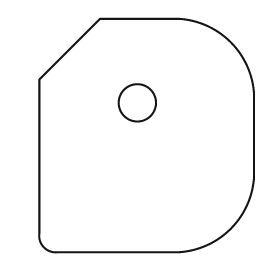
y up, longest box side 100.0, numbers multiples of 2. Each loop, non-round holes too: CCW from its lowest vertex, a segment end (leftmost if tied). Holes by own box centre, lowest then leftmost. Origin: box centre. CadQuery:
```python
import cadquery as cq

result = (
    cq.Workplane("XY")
    .moveTo(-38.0, -50.0)
    .lineTo(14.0, -50.0)
    .threePointArc((36.0, -40.0), (46.0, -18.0))
    .lineTo(46.0, 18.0)
    .threePointArc((36.0, 40.0), (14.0, 50.0))
    .lineTo(-20.0, 50.0)
    .lineTo(-46.0, 24.0)
    .lineTo(-46.0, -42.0)
    .threePointArc((-44.0, -48.0), (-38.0, -50.0))
    .close()
    .moveTo(-4.0, 14.0)
    .circle(8.0)
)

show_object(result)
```